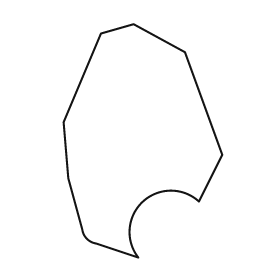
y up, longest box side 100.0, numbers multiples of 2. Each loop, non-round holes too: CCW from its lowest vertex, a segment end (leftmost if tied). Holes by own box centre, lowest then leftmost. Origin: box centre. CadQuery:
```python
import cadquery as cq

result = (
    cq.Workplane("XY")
    .moveTo(-2.0, -50.0)
    .threePointArc((0.0, -26.0), (24.0, -26.0))
    .lineTo(34.0, -6.0)
    .lineTo(18.0, 38.0)
    .lineTo(-4.0, 50.0)
    .lineTo(-18.0, 46.0)
    .lineTo(-34.0, 8.0)
    .lineTo(-32.0, -16.0)
    .lineTo(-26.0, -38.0)
    .threePointArc((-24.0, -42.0), (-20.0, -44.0))
    .close()
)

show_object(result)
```